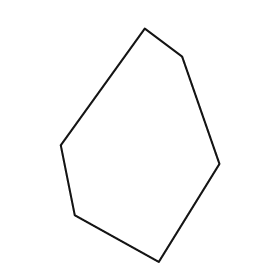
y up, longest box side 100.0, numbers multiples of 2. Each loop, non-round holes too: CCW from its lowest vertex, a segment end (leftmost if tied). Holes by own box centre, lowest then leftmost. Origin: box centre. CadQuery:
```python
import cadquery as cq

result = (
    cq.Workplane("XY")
    .moveTo(8.0, -50.0)
    .lineTo(34.0, -8.0)
    .lineTo(18.0, 38.0)
    .lineTo(2.0, 50.0)
    .lineTo(-34.0, 0.0)
    .lineTo(-28.0, -30.0)
    .close()
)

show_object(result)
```